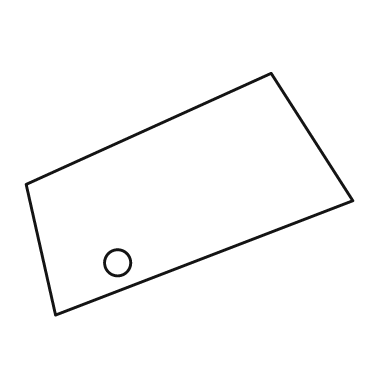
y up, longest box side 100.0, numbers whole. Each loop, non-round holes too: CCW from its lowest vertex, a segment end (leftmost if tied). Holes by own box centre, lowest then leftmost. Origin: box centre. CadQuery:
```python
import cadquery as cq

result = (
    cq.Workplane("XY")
    .moveTo(-41.0, -37.0)
    .lineTo(50.0, -2.0)
    .lineTo(25.0, 37.0)
    .lineTo(-50.0, 3.0)
    .close()
    .moveTo(-22.0, -21.0)
    .circle(4.0)
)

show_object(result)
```